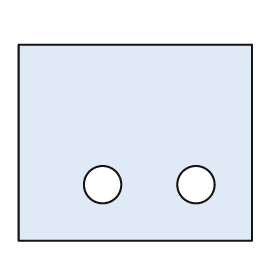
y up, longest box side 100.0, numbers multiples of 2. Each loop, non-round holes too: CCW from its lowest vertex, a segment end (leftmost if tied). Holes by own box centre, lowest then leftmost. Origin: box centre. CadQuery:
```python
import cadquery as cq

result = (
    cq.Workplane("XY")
    .moveTo(-50.0, -42.0)
    .lineTo(50.0, -42.0)
    .lineTo(50.0, 42.0)
    .lineTo(-50.0, 42.0)
    .close()
    .moveTo(-14.0, -18.0)
    .circle(8.0)
    .moveTo(26.0, -18.0)
    .circle(8.0)
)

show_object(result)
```